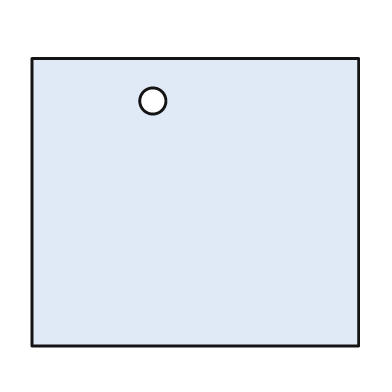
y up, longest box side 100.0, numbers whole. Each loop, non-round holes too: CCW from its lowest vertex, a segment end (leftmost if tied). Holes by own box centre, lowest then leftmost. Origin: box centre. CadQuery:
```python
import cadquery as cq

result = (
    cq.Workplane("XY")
    .moveTo(-50.0, -44.0)
    .lineTo(50.0, -44.0)
    .lineTo(50.0, 44.0)
    .lineTo(-50.0, 44.0)
    .close()
    .moveTo(-13.0, 31.0)
    .circle(4.0)
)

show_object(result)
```